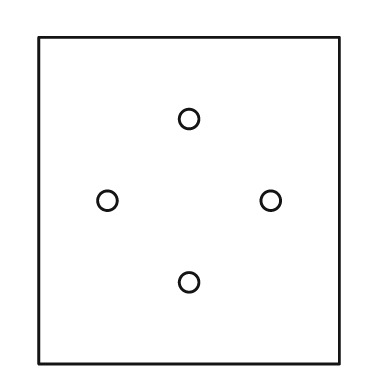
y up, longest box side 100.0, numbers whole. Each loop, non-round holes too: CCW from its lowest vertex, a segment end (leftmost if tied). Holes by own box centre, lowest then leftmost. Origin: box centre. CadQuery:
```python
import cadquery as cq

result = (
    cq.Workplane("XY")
    .moveTo(-46.0, -50.0)
    .lineTo(46.0, -50.0)
    .lineTo(46.0, 50.0)
    .lineTo(-46.0, 50.0)
    .close()
    .moveTo(0.0, -25.0)
    .circle(3.0)
    .moveTo(-25.0, 0.0)
    .circle(3.0)
    .moveTo(25.0, 0.0)
    .circle(3.0)
    .moveTo(0.0, 25.0)
    .circle(3.0)
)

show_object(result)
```